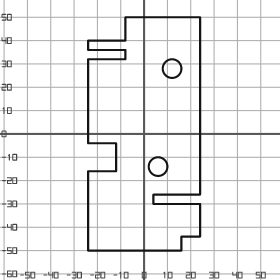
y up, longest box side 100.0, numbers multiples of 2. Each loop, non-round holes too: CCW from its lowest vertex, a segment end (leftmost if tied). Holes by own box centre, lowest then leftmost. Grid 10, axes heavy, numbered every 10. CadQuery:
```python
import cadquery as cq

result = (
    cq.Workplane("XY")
    .moveTo(-24.0, -50.0)
    .lineTo(16.0, -50.0)
    .lineTo(16.0, -44.0)
    .lineTo(24.0, -44.0)
    .lineTo(24.0, -30.0)
    .lineTo(4.0, -30.0)
    .lineTo(4.0, -26.0)
    .lineTo(24.0, -26.0)
    .lineTo(24.0, 50.0)
    .lineTo(-8.0, 50.0)
    .lineTo(-8.0, 40.0)
    .lineTo(-24.0, 40.0)
    .lineTo(-24.0, 36.0)
    .lineTo(-8.0, 36.0)
    .lineTo(-8.0, 32.0)
    .lineTo(-24.0, 32.0)
    .lineTo(-24.0, -4.0)
    .lineTo(-12.0, -4.0)
    .lineTo(-12.0, -16.0)
    .lineTo(-24.0, -16.0)
    .close()
    .moveTo(6.0, -14.0)
    .circle(4.0)
    .moveTo(12.0, 28.0)
    .circle(4.0)
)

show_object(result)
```